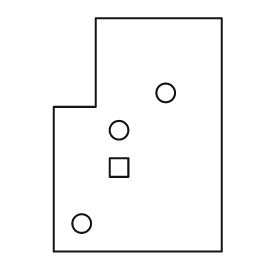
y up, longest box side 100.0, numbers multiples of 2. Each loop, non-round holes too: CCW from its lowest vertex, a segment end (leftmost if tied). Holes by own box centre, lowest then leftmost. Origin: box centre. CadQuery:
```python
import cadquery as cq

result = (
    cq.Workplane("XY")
    .moveTo(-36.0, -50.0)
    .lineTo(36.0, -50.0)
    .lineTo(36.0, 50.0)
    .lineTo(-18.0, 50.0)
    .lineTo(-18.0, 12.0)
    .lineTo(-36.0, 12.0)
    .close()
    .moveTo(-24.0, -38.0)
    .circle(4.0)
    .moveTo(-12.0, -18.0)
    .lineTo(-4.0, -18.0)
    .lineTo(-4.0, -10.0)
    .lineTo(-12.0, -10.0)
    .close()
    .moveTo(-8.0, 2.0)
    .circle(4.0)
    .moveTo(12.0, 18.0)
    .circle(4.0)
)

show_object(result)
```